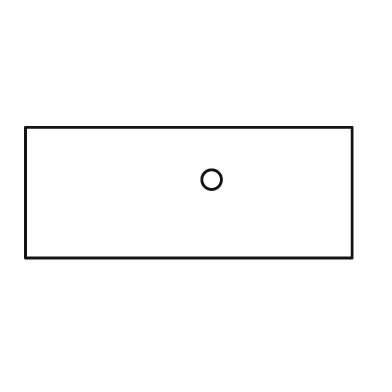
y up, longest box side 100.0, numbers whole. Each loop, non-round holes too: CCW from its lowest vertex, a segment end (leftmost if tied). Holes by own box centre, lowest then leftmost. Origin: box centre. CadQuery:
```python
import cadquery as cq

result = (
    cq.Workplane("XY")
    .moveTo(-50.0, -20.0)
    .lineTo(50.0, -20.0)
    .lineTo(50.0, 20.0)
    .lineTo(-50.0, 20.0)
    .close()
    .moveTo(7.0, 4.0)
    .circle(3.0)
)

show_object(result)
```